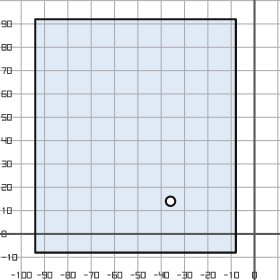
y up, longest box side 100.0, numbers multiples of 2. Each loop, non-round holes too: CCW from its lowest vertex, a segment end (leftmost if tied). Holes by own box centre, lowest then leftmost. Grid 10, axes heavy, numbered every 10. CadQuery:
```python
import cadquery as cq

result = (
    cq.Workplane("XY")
    .moveTo(-94.0, -8.0)
    .lineTo(-8.0, -8.0)
    .lineTo(-8.0, 92.0)
    .lineTo(-94.0, 92.0)
    .close()
    .moveTo(-36.0, 14.0)
    .circle(2.0)
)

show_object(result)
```